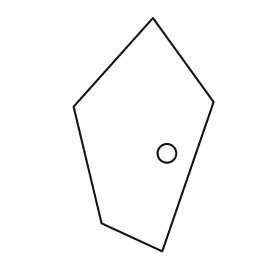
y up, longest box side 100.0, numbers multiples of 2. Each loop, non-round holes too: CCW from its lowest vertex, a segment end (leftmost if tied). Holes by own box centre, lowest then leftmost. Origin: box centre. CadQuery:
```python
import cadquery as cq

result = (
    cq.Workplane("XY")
    .moveTo(8.0, -50.0)
    .lineTo(30.0, 14.0)
    .lineTo(4.0, 50.0)
    .lineTo(-30.0, 12.0)
    .lineTo(-18.0, -38.0)
    .close()
    .moveTo(10.0, -8.0)
    .circle(4.0)
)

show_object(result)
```